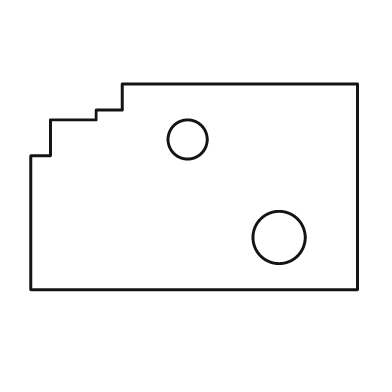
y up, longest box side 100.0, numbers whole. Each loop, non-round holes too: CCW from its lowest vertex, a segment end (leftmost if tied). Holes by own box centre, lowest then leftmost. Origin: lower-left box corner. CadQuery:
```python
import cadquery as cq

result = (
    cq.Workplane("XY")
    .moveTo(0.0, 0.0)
    .lineTo(100.0, 0.0)
    .lineTo(100.0, 63.0)
    .lineTo(28.0, 63.0)
    .lineTo(28.0, 55.0)
    .lineTo(20.0, 55.0)
    .lineTo(20.0, 52.0)
    .lineTo(6.0, 52.0)
    .lineTo(6.0, 41.0)
    .lineTo(0.0, 41.0)
    .close()
    .moveTo(76.0, 16.0)
    .circle(8.0)
    .moveTo(48.0, 46.0)
    .circle(6.0)
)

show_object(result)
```